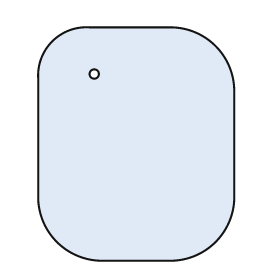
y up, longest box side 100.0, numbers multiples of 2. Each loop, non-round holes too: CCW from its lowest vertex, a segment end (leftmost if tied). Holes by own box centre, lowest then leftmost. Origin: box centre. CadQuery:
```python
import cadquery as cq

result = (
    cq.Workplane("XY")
    .moveTo(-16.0, -50.0)
    .lineTo(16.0, -50.0)
    .threePointArc((34.0, -42.0), (42.0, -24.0))
    .lineTo(42.0, 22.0)
    .threePointArc((34.0, 42.0), (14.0, 50.0))
    .lineTo(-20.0, 50.0)
    .threePointArc((-36.0, 44.0), (-42.0, 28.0))
    .lineTo(-42.0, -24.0)
    .threePointArc((-34.0, -42.0), (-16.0, -50.0))
    .close()
    .moveTo(-18.0, 30.0)
    .circle(2.0)
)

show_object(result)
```